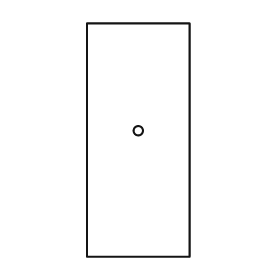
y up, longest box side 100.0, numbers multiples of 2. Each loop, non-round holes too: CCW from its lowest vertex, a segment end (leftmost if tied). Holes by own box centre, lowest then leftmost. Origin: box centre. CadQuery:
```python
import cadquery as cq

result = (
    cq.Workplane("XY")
    .moveTo(-22.0, -50.0)
    .lineTo(22.0, -50.0)
    .lineTo(22.0, 50.0)
    .lineTo(-22.0, 50.0)
    .close()
    .moveTo(0.0, 4.0)
    .circle(2.0)
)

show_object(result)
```